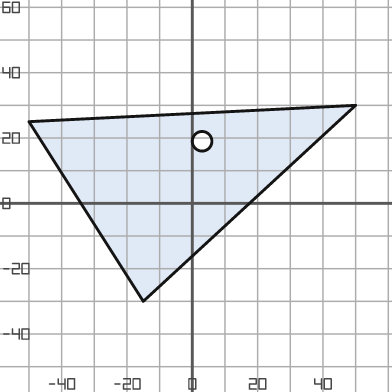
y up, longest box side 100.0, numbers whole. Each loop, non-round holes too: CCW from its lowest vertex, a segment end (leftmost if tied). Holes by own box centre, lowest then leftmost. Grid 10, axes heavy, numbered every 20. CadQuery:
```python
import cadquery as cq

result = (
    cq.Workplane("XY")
    .moveTo(-15.0, -30.0)
    .lineTo(50.0, 30.0)
    .lineTo(-50.0, 25.0)
    .close()
    .moveTo(3.0, 19.0)
    .circle(3.0)
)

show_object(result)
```